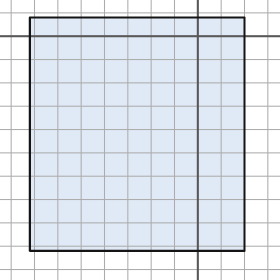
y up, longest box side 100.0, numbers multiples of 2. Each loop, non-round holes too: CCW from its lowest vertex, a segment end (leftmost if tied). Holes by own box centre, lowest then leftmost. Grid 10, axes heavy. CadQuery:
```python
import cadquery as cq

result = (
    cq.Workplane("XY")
    .moveTo(-72.0, -92.0)
    .lineTo(20.0, -92.0)
    .lineTo(20.0, 8.0)
    .lineTo(-72.0, 8.0)
    .close()
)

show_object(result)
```